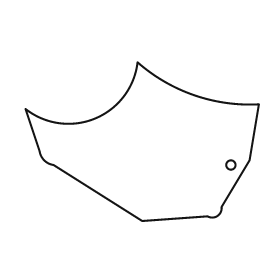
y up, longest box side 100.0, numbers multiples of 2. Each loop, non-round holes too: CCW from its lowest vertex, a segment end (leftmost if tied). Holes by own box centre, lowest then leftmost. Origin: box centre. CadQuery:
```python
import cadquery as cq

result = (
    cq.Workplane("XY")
    .moveTo(0.0, -34.0)
    .lineTo(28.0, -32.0)
    .threePointArc((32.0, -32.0), (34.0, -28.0))
    .lineTo(46.0, -8.0)
    .lineTo(50.0, 16.0)
    .threePointArc((22.0, 20.0), (-2.0, 34.0))
    .threePointArc((-20.0, 10.0), (-50.0, 14.0))
    .lineTo(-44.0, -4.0)
    .threePointArc((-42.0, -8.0), (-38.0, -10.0))
    .close()
    .moveTo(38.0, -10.0)
    .circle(2.0)
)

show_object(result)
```